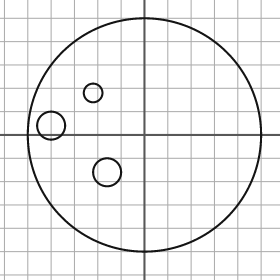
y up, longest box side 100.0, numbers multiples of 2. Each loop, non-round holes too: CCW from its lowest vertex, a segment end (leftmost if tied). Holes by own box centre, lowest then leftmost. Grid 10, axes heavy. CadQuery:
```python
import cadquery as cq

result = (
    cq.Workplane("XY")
    .moveTo(0.0, 0.0)
    .circle(50.0)
    .moveTo(-16.0, -16.0)
    .circle(6.0)
    .moveTo(-40.0, 4.0)
    .circle(6.0)
    .moveTo(-22.0, 18.0)
    .circle(4.0)
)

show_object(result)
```